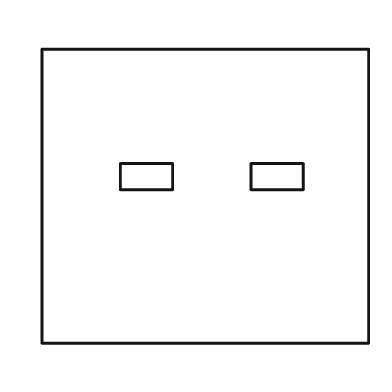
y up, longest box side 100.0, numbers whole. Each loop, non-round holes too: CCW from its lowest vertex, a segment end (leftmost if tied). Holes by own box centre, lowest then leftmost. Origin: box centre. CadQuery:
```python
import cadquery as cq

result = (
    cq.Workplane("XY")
    .moveTo(-50.0, -45.0)
    .lineTo(50.0, -45.0)
    .lineTo(50.0, 45.0)
    .lineTo(-50.0, 45.0)
    .close()
    .moveTo(-26.0, 2.0)
    .lineTo(-10.0, 2.0)
    .lineTo(-10.0, 10.0)
    .lineTo(-26.0, 10.0)
    .close()
    .moveTo(14.0, 2.0)
    .lineTo(30.0, 2.0)
    .lineTo(30.0, 10.0)
    .lineTo(14.0, 10.0)
    .close()
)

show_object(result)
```